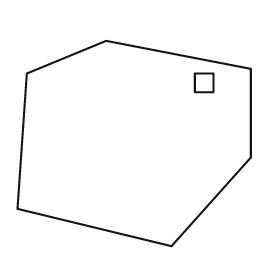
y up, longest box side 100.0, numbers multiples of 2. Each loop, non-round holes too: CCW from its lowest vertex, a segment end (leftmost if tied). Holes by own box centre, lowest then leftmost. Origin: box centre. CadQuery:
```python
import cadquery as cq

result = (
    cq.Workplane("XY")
    .moveTo(16.0, -44.0)
    .lineTo(50.0, -6.0)
    .lineTo(50.0, 32.0)
    .lineTo(-12.0, 44.0)
    .lineTo(-46.0, 30.0)
    .lineTo(-50.0, -28.0)
    .close()
    .moveTo(26.0, 22.0)
    .lineTo(34.0, 22.0)
    .lineTo(34.0, 30.0)
    .lineTo(26.0, 30.0)
    .close()
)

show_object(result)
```